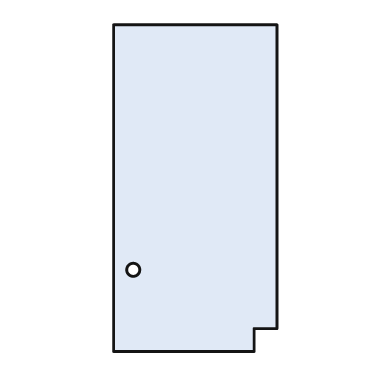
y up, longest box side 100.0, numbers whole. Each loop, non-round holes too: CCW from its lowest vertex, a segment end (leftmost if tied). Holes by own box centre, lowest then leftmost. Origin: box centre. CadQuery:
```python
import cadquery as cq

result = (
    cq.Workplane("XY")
    .moveTo(-25.0, -50.0)
    .lineTo(18.0, -50.0)
    .lineTo(18.0, -43.0)
    .lineTo(25.0, -43.0)
    .lineTo(25.0, 50.0)
    .lineTo(-25.0, 50.0)
    .close()
    .moveTo(-19.0, -25.0)
    .circle(2.0)
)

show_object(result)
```